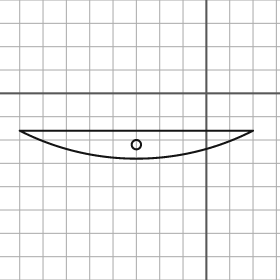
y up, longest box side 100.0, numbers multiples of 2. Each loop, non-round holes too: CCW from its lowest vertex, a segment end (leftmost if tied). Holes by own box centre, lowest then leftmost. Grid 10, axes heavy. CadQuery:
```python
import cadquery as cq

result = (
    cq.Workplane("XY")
    .moveTo(-80.0, -16.0)
    .threePointArc((-30.0, -28.0), (20.0, -16.0))
    .close()
    .moveTo(-30.0, -22.0)
    .circle(2.0)
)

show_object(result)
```